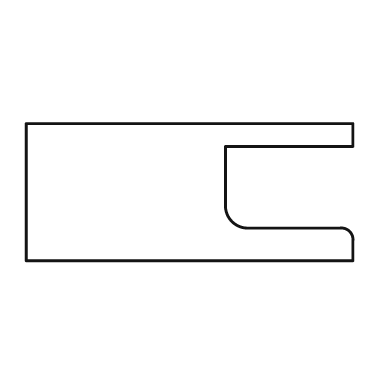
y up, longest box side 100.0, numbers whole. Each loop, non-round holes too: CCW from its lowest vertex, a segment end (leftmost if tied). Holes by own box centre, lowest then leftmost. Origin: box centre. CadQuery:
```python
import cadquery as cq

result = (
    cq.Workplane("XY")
    .moveTo(-50.0, -21.0)
    .lineTo(50.0, -21.0)
    .lineTo(50.0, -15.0)
    .threePointArc((49.0, -12.0), (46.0, -11.0))
    .lineTo(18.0, -11.0)
    .threePointArc((13.0, -9.0), (11.0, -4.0))
    .lineTo(11.0, 14.0)
    .lineTo(50.0, 14.0)
    .lineTo(50.0, 21.0)
    .lineTo(-50.0, 21.0)
    .close()
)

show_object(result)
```